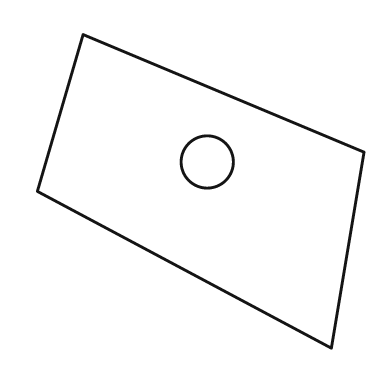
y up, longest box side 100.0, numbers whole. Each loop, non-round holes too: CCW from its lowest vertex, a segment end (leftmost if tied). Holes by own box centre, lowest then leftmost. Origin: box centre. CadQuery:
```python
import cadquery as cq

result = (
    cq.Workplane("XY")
    .moveTo(40.0, -48.0)
    .lineTo(50.0, 12.0)
    .lineTo(-36.0, 48.0)
    .lineTo(-50.0, 0.0)
    .close()
    .moveTo(2.0, 9.0)
    .circle(8.0)
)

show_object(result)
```